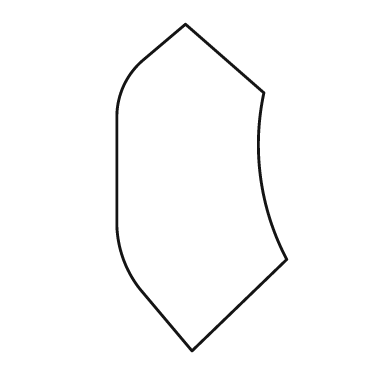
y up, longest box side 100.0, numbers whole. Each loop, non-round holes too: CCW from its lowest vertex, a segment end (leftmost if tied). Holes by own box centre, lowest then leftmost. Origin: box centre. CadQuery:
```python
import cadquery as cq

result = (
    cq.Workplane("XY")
    .moveTo(-3.0, -50.0)
    .lineTo(26.0, -22.0)
    .threePointArc((18.0, 3.0), (19.0, 29.0))
    .lineTo(-5.0, 50.0)
    .lineTo(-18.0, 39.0)
    .threePointArc((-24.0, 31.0), (-26.0, 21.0))
    .lineTo(-26.0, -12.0)
    .threePointArc((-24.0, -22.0), (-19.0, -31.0))
    .close()
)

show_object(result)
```